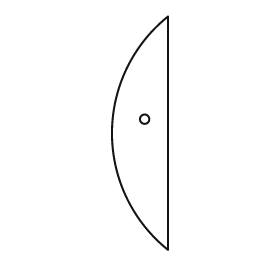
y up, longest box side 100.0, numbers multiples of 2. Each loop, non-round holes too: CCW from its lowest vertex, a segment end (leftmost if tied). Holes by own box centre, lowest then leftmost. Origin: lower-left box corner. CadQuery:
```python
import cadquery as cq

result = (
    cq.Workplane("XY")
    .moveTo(24.0, 0.0)
    .lineTo(24.0, 100.0)
    .threePointArc((0.0, 50.0), (24.0, 0.0))
    .close()
    .moveTo(14.0, 56.0)
    .circle(2.0)
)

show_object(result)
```